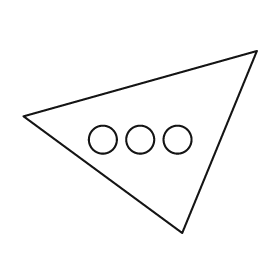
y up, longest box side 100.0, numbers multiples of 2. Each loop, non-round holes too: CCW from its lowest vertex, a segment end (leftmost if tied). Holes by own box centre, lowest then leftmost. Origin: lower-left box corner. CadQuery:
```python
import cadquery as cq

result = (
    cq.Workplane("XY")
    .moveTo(68.0, 0.0)
    .lineTo(100.0, 78.0)
    .lineTo(0.0, 50.0)
    .close()
    .moveTo(34.0, 40.0)
    .circle(6.0)
    .moveTo(50.0, 40.0)
    .circle(6.0)
    .moveTo(66.0, 40.0)
    .circle(6.0)
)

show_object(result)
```